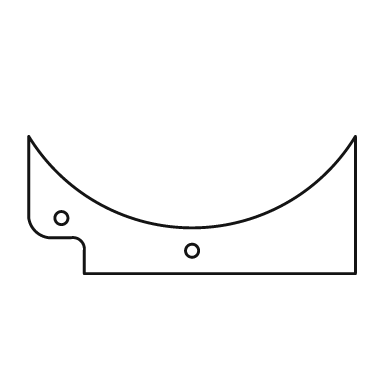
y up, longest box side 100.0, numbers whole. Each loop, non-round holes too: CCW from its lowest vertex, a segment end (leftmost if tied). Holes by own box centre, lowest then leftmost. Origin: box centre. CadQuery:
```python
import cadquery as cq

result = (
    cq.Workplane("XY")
    .moveTo(-33.0, -21.0)
    .lineTo(50.0, -21.0)
    .lineTo(50.0, 21.0)
    .threePointArc((0.0, -7.0), (-50.0, 21.0))
    .lineTo(-50.0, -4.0)
    .threePointArc((-48.0, -8.0), (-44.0, -10.0))
    .lineTo(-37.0, -10.0)
    .threePointArc((-34.0, -11.0), (-33.0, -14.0))
    .close()
    .moveTo(0.0, -14.0)
    .circle(2.0)
    .moveTo(-40.0, -4.0)
    .circle(2.0)
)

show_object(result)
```